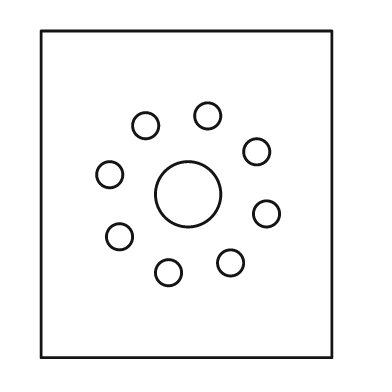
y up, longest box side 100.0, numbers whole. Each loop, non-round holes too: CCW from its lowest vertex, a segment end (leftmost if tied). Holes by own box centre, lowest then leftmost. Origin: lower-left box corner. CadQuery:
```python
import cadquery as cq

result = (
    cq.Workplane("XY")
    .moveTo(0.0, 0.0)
    .lineTo(89.0, 0.0)
    .lineTo(89.0, 100.0)
    .lineTo(0.0, 100.0)
    .close()
    .moveTo(39.0, 26.0)
    .circle(4.0)
    .moveTo(58.0, 29.0)
    .circle(4.0)
    .moveTo(24.0, 37.0)
    .circle(4.0)
    .moveTo(69.0, 44.0)
    .circle(4.0)
    .moveTo(45.0, 50.0)
    .circle(10.0)
    .moveTo(21.0, 56.0)
    .circle(4.0)
    .moveTo(66.0, 63.0)
    .circle(4.0)
    .moveTo(32.0, 71.0)
    .circle(4.0)
    .moveTo(51.0, 74.0)
    .circle(4.0)
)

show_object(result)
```